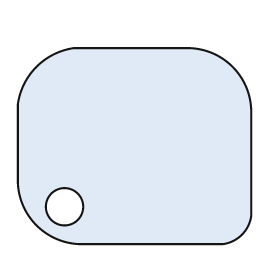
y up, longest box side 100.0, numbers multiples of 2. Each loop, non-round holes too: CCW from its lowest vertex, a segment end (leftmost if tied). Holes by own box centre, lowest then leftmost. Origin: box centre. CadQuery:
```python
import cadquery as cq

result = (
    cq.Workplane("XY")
    .moveTo(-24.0, -42.0)
    .lineTo(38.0, -42.0)
    .threePointArc((46.0, -38.0), (50.0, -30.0))
    .lineTo(50.0, 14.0)
    .threePointArc((42.0, 34.0), (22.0, 42.0))
    .lineTo(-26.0, 42.0)
    .threePointArc((-42.0, 34.0), (-50.0, 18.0))
    .lineTo(-50.0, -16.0)
    .threePointArc((-42.0, -34.0), (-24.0, -42.0))
    .close()
    .moveTo(-30.0, -26.0)
    .circle(8.0)
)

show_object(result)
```